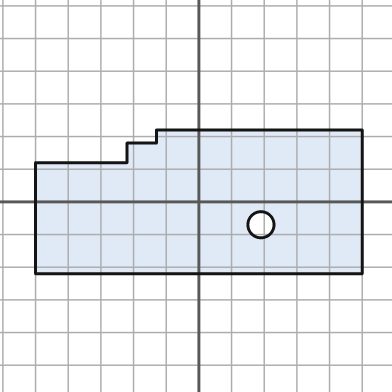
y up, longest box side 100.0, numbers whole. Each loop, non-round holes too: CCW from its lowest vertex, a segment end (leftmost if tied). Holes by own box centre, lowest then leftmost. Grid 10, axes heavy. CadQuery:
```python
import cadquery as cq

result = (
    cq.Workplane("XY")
    .moveTo(-50.0, -22.0)
    .lineTo(50.0, -22.0)
    .lineTo(50.0, 22.0)
    .lineTo(-13.0, 22.0)
    .lineTo(-13.0, 18.0)
    .lineTo(-22.0, 18.0)
    .lineTo(-22.0, 12.0)
    .lineTo(-50.0, 12.0)
    .close()
    .moveTo(19.0, -7.0)
    .circle(4.0)
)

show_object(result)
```